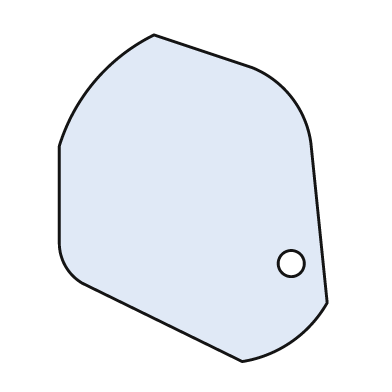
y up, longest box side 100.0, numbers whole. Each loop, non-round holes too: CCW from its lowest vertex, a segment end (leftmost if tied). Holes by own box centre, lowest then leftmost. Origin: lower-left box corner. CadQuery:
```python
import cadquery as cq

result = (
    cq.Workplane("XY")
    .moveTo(56.0, 0.0)
    .threePointArc((71.0, 6.0), (82.0, 18.0))
    .lineTo(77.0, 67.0)
    .threePointArc((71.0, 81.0), (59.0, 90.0))
    .lineTo(29.0, 100.0)
    .threePointArc((11.0, 86.0), (0.0, 66.0))
    .lineTo(0.0, 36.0)
    .threePointArc((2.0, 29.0), (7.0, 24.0))
    .close()
    .moveTo(71.0, 30.0)
    .circle(4.0)
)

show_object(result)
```